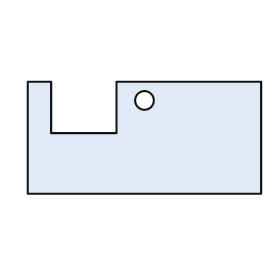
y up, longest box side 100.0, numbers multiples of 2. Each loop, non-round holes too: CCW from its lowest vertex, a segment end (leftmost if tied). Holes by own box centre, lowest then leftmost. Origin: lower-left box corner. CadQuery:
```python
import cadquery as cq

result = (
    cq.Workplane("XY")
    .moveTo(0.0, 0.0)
    .lineTo(100.0, 0.0)
    .lineTo(100.0, 48.0)
    .lineTo(38.0, 48.0)
    .lineTo(38.0, 26.0)
    .lineTo(10.0, 26.0)
    .lineTo(10.0, 48.0)
    .lineTo(0.0, 48.0)
    .close()
    .moveTo(50.0, 40.0)
    .circle(4.0)
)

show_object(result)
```